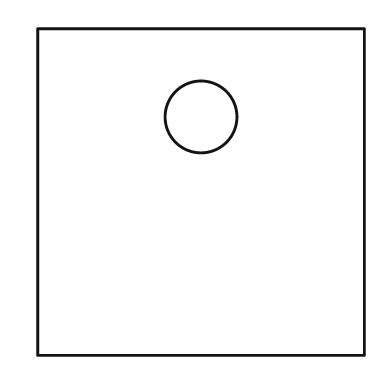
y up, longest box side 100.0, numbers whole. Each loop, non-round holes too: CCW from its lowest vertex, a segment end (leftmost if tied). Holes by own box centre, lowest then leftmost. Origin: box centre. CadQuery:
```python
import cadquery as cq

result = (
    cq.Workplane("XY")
    .moveTo(-50.0, -50.0)
    .lineTo(50.0, -50.0)
    .lineTo(50.0, 50.0)
    .lineTo(-50.0, 50.0)
    .close()
    .moveTo(0.0, 23.0)
    .circle(11.0)
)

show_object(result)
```